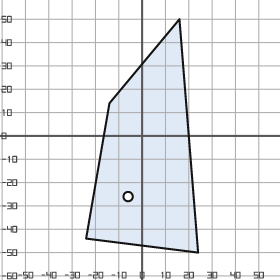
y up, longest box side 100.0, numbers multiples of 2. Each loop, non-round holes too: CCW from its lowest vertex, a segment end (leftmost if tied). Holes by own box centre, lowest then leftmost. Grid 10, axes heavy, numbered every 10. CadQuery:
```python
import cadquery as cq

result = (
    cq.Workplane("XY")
    .moveTo(24.0, -50.0)
    .lineTo(16.0, 50.0)
    .lineTo(-14.0, 14.0)
    .lineTo(-24.0, -44.0)
    .close()
    .moveTo(-6.0, -26.0)
    .circle(2.0)
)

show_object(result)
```